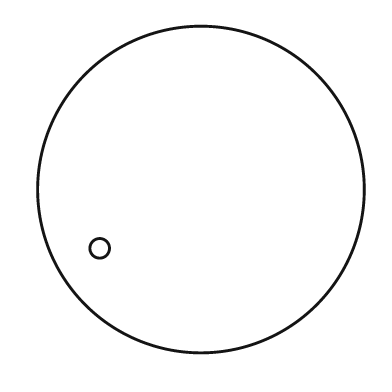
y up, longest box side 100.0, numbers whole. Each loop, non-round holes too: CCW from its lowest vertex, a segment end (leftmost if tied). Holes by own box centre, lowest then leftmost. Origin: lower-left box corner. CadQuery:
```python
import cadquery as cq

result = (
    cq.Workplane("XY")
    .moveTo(50.0, 50.0)
    .circle(50.0)
    .moveTo(19.0, 32.0)
    .circle(3.0)
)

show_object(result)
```